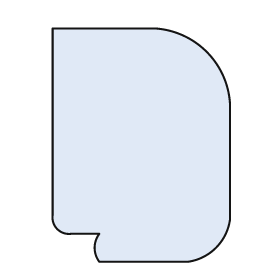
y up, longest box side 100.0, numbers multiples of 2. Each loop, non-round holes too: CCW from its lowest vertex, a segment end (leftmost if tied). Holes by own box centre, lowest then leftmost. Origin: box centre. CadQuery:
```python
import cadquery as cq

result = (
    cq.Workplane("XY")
    .moveTo(-18.0, -50.0)
    .lineTo(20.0, -50.0)
    .threePointArc((32.0, -44.0), (38.0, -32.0))
    .lineTo(38.0, 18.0)
    .threePointArc((28.0, 40.0), (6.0, 50.0))
    .lineTo(-38.0, 50.0)
    .lineTo(-38.0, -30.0)
    .threePointArc((-36.0, -36.0), (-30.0, -38.0))
    .lineTo(-18.0, -38.0)
    .threePointArc((-20.0, -44.0), (-18.0, -50.0))
    .close()
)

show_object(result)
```